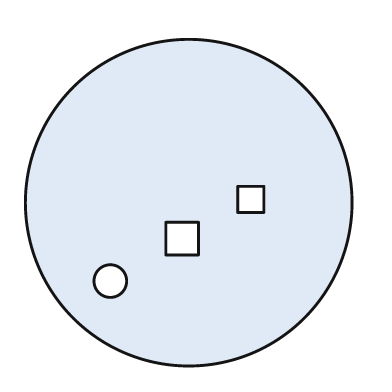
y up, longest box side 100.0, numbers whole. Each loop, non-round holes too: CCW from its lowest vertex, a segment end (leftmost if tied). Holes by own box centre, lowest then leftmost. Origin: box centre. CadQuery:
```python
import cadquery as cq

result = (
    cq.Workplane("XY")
    .moveTo(0.0, 0.0)
    .circle(50.0)
    .moveTo(-24.0, -24.0)
    .circle(5.0)
    .moveTo(-7.0, -16.0)
    .lineTo(3.0, -16.0)
    .lineTo(3.0, -6.0)
    .lineTo(-7.0, -6.0)
    .close()
    .moveTo(15.0, -3.0)
    .lineTo(23.0, -3.0)
    .lineTo(23.0, 5.0)
    .lineTo(15.0, 5.0)
    .close()
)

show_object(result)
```